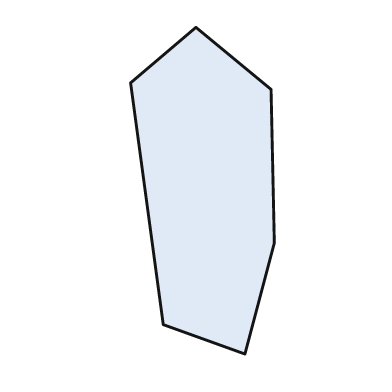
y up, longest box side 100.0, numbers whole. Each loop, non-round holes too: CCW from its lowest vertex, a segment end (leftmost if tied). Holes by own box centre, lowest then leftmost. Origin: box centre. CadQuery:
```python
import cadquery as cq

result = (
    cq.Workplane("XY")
    .moveTo(13.0, -50.0)
    .lineTo(22.0, -16.0)
    .lineTo(21.0, 31.0)
    .lineTo(-2.0, 50.0)
    .lineTo(-22.0, 33.0)
    .lineTo(-12.0, -41.0)
    .close()
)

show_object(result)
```